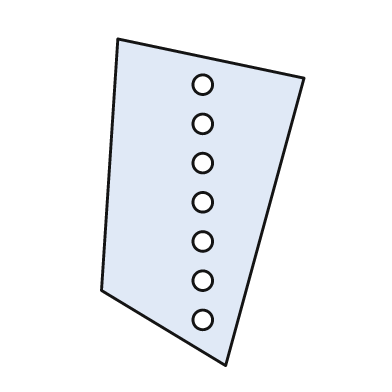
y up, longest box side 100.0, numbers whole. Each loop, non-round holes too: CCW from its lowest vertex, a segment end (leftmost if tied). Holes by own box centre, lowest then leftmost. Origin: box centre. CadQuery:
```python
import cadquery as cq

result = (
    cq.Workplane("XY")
    .moveTo(7.0, -50.0)
    .lineTo(31.0, 38.0)
    .lineTo(-26.0, 50.0)
    .lineTo(-31.0, -27.0)
    .close()
    .moveTo(0.0, -36.0)
    .circle(3.0)
    .moveTo(0.0, -24.0)
    .circle(3.0)
    .moveTo(0.0, -12.0)
    .circle(3.0)
    .moveTo(0.0, 0.0)
    .circle(3.0)
    .moveTo(0.0, 12.0)
    .circle(3.0)
    .moveTo(0.0, 24.0)
    .circle(3.0)
    .moveTo(0.0, 36.0)
    .circle(3.0)
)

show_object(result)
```